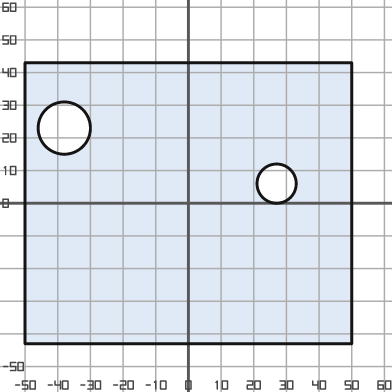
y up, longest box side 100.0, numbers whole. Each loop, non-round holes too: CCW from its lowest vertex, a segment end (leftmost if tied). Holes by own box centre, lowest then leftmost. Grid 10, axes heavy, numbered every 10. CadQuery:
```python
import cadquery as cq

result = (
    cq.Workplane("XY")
    .moveTo(-50.0, -43.0)
    .lineTo(50.0, -43.0)
    .lineTo(50.0, 43.0)
    .lineTo(-50.0, 43.0)
    .close()
    .moveTo(27.0, 6.0)
    .circle(6.0)
    .moveTo(-38.0, 23.0)
    .circle(8.0)
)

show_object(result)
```